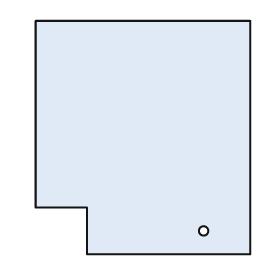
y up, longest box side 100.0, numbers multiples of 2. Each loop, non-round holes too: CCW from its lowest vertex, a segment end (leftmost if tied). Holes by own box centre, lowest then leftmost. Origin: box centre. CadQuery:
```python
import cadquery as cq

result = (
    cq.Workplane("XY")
    .moveTo(-24.0, -50.0)
    .lineTo(46.0, -50.0)
    .lineTo(46.0, 50.0)
    .lineTo(-46.0, 50.0)
    .lineTo(-46.0, -30.0)
    .lineTo(-24.0, -30.0)
    .close()
    .moveTo(26.0, -40.0)
    .circle(2.0)
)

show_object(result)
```